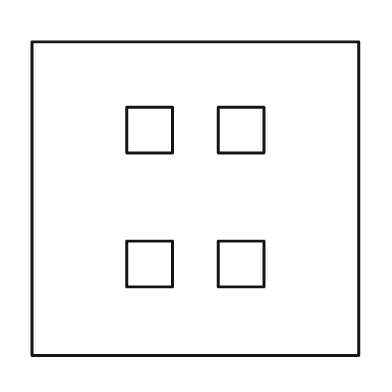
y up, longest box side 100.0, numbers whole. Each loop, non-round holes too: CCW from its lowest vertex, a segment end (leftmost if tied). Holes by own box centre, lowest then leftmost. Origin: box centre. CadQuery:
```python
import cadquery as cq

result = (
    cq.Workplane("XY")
    .moveTo(-50.0, -48.0)
    .lineTo(50.0, -48.0)
    .lineTo(50.0, 48.0)
    .lineTo(-50.0, 48.0)
    .close()
    .moveTo(-21.0, -27.0)
    .lineTo(-7.0, -27.0)
    .lineTo(-7.0, -13.0)
    .lineTo(-21.0, -13.0)
    .close()
    .moveTo(7.0, -27.0)
    .lineTo(21.0, -27.0)
    .lineTo(21.0, -13.0)
    .lineTo(7.0, -13.0)
    .close()
    .moveTo(-21.0, 14.0)
    .lineTo(-7.0, 14.0)
    .lineTo(-7.0, 28.0)
    .lineTo(-21.0, 28.0)
    .close()
    .moveTo(7.0, 14.0)
    .lineTo(21.0, 14.0)
    .lineTo(21.0, 28.0)
    .lineTo(7.0, 28.0)
    .close()
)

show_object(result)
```